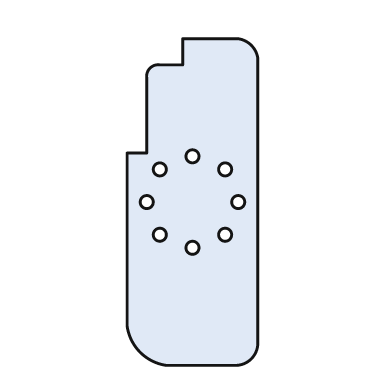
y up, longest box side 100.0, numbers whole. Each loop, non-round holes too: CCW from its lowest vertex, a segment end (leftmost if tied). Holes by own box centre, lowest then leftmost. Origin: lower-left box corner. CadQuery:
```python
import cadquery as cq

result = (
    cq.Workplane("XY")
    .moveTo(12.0, 0.0)
    .lineTo(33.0, 0.0)
    .threePointArc((38.0, 2.0), (40.0, 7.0))
    .lineTo(40.0, 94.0)
    .threePointArc((38.0, 98.0), (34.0, 100.0))
    .lineTo(17.0, 100.0)
    .lineTo(17.0, 92.0)
    .lineTo(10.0, 92.0)
    .threePointArc((7.0, 91.0), (6.0, 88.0))
    .lineTo(6.0, 65.0)
    .lineTo(0.0, 65.0)
    .lineTo(0.0, 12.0)
    .threePointArc((4.0, 4.0), (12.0, 0.0))
    .close()
    .moveTo(20.0, 36.0)
    .circle(2.0)
    .moveTo(10.0, 40.0)
    .circle(2.0)
    .moveTo(30.0, 40.0)
    .circle(2.0)
    .moveTo(6.0, 50.0)
    .circle(2.0)
    .moveTo(34.0, 50.0)
    .circle(2.0)
    .moveTo(10.0, 60.0)
    .circle(2.0)
    .moveTo(30.0, 60.0)
    .circle(2.0)
    .moveTo(20.0, 64.0)
    .circle(2.0)
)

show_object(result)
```